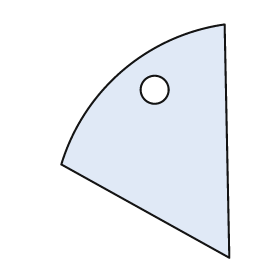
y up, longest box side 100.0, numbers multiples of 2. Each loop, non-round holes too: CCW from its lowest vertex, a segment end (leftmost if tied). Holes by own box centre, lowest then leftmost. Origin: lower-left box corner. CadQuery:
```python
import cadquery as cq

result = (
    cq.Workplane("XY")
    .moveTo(72.0, 0.0)
    .lineTo(70.0, 100.0)
    .threePointArc((26.0, 80.0), (0.0, 40.0))
    .close()
    .moveTo(40.0, 72.0)
    .circle(6.0)
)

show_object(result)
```